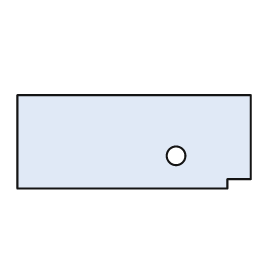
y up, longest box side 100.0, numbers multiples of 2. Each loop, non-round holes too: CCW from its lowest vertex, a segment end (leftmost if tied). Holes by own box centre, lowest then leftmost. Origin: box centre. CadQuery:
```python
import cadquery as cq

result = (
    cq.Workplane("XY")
    .moveTo(-50.0, -20.0)
    .lineTo(40.0, -20.0)
    .lineTo(40.0, -16.0)
    .lineTo(50.0, -16.0)
    .lineTo(50.0, 20.0)
    .lineTo(-50.0, 20.0)
    .close()
    .moveTo(18.0, -6.0)
    .circle(4.0)
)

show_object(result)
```